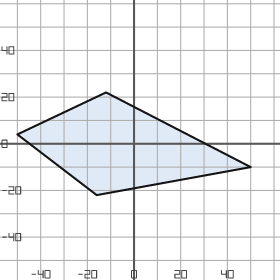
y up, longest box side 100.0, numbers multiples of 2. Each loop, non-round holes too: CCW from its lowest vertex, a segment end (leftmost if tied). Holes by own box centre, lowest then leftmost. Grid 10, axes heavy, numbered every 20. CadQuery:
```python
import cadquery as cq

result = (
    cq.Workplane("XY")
    .moveTo(-16.0, -22.0)
    .lineTo(50.0, -10.0)
    .lineTo(-12.0, 22.0)
    .lineTo(-50.0, 4.0)
    .close()
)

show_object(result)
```